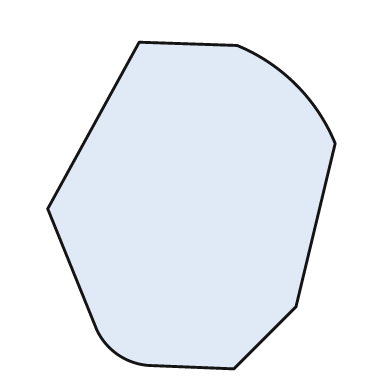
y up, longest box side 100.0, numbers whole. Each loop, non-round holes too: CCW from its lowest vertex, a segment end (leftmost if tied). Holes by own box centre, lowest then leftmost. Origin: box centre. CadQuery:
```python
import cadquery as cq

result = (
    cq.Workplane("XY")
    .moveTo(13.0, -50.0)
    .lineTo(32.0, -31.0)
    .lineTo(44.0, 19.0)
    .threePointArc((32.0, 37.0), (14.0, 49.0))
    .lineTo(-16.0, 50.0)
    .lineTo(-44.0, -1.0)
    .lineTo(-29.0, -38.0)
    .threePointArc((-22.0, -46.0), (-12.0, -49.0))
    .close()
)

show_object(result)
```